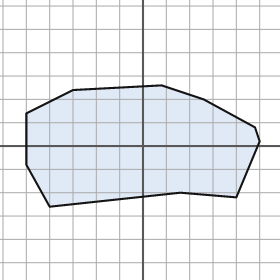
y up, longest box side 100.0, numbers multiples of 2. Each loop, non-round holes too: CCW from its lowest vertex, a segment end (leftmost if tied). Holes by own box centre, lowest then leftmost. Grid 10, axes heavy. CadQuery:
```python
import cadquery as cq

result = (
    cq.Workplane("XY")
    .moveTo(-40.0, -26.0)
    .lineTo(16.0, -20.0)
    .lineTo(40.0, -22.0)
    .lineTo(50.0, 2.0)
    .lineTo(48.0, 8.0)
    .lineTo(26.0, 20.0)
    .lineTo(8.0, 26.0)
    .lineTo(-30.0, 24.0)
    .lineTo(-50.0, 14.0)
    .lineTo(-50.0, -8.0)
    .close()
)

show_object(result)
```